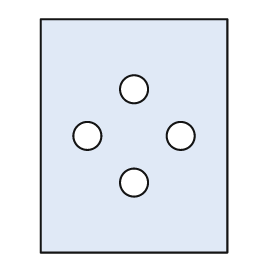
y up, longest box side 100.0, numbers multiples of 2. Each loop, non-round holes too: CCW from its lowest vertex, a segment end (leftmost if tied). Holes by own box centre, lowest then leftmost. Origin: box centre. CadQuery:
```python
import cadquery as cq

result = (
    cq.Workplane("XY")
    .moveTo(-40.0, -50.0)
    .lineTo(40.0, -50.0)
    .lineTo(40.0, 50.0)
    .lineTo(-40.0, 50.0)
    .close()
    .moveTo(0.0, -20.0)
    .circle(6.0)
    .moveTo(-20.0, 0.0)
    .circle(6.0)
    .moveTo(20.0, 0.0)
    .circle(6.0)
    .moveTo(0.0, 20.0)
    .circle(6.0)
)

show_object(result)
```